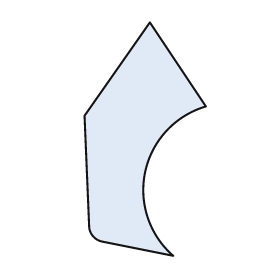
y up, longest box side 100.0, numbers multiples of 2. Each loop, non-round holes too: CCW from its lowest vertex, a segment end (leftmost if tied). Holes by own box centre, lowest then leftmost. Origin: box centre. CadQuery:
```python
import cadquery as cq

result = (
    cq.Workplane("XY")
    .moveTo(12.0, -50.0)
    .threePointArc((0.0, -14.0), (26.0, 14.0))
    .lineTo(2.0, 50.0)
    .lineTo(-26.0, 10.0)
    .lineTo(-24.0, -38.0)
    .threePointArc((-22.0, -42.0), (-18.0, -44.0))
    .close()
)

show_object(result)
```